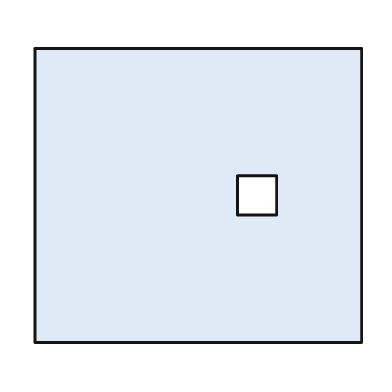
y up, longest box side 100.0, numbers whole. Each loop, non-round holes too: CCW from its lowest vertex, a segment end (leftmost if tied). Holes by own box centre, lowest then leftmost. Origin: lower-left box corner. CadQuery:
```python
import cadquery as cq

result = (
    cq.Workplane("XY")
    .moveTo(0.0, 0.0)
    .lineTo(100.0, 0.0)
    .lineTo(100.0, 90.0)
    .lineTo(0.0, 90.0)
    .close()
    .moveTo(62.0, 39.0)
    .lineTo(74.0, 39.0)
    .lineTo(74.0, 51.0)
    .lineTo(62.0, 51.0)
    .close()
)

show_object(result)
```